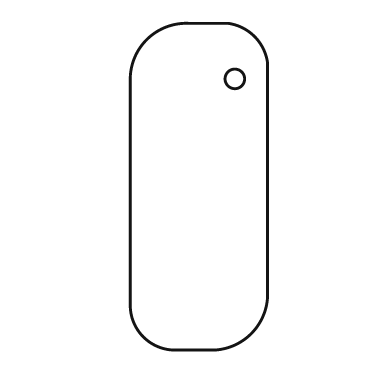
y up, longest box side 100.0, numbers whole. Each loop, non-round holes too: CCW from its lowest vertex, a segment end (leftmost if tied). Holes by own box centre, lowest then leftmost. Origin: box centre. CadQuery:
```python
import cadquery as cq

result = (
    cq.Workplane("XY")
    .moveTo(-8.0, -50.0)
    .lineTo(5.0, -50.0)
    .threePointArc((16.0, -45.0), (21.0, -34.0))
    .lineTo(21.0, 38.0)
    .threePointArc((17.0, 46.0), (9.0, 50.0))
    .lineTo(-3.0, 50.0)
    .threePointArc((-16.0, 45.0), (-21.0, 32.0))
    .lineTo(-21.0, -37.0)
    .threePointArc((-17.0, -46.0), (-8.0, -50.0))
    .close()
    .moveTo(11.0, 33.0)
    .circle(3.0)
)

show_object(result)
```